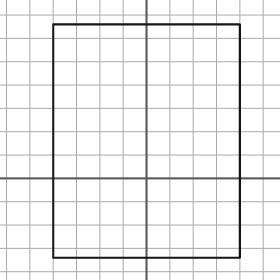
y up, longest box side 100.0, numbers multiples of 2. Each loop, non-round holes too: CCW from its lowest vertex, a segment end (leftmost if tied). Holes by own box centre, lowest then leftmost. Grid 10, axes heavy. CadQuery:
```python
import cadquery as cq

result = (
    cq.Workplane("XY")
    .moveTo(-40.0, -34.0)
    .lineTo(40.0, -34.0)
    .lineTo(40.0, 66.0)
    .lineTo(-40.0, 66.0)
    .close()
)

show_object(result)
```